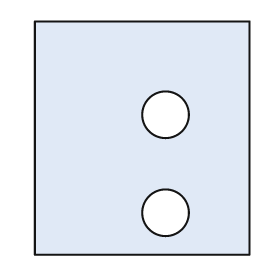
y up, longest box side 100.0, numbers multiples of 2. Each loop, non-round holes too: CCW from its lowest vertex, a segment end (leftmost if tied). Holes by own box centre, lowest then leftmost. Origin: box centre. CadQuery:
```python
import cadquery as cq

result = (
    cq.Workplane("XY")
    .moveTo(-46.0, -50.0)
    .lineTo(46.0, -50.0)
    .lineTo(46.0, 50.0)
    .lineTo(-46.0, 50.0)
    .close()
    .moveTo(10.0, -32.0)
    .circle(10.0)
    .moveTo(10.0, 10.0)
    .circle(10.0)
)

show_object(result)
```